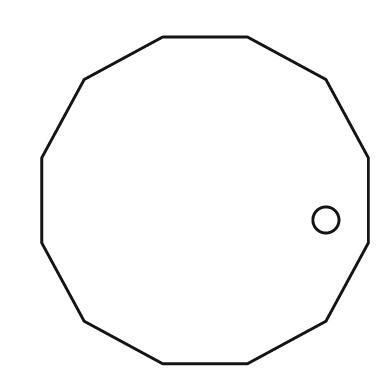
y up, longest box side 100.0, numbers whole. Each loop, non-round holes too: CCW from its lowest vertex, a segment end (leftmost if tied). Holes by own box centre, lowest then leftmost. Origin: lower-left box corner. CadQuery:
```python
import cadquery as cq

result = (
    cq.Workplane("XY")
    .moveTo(37.0, 0.0)
    .lineTo(63.0, 0.0)
    .lineTo(87.0, 13.0)
    .lineTo(100.0, 37.0)
    .lineTo(100.0, 63.0)
    .lineTo(87.0, 87.0)
    .lineTo(63.0, 100.0)
    .lineTo(37.0, 100.0)
    .lineTo(13.0, 87.0)
    .lineTo(0.0, 63.0)
    .lineTo(0.0, 37.0)
    .lineTo(13.0, 13.0)
    .close()
    .moveTo(87.0, 44.0)
    .circle(4.0)
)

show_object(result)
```